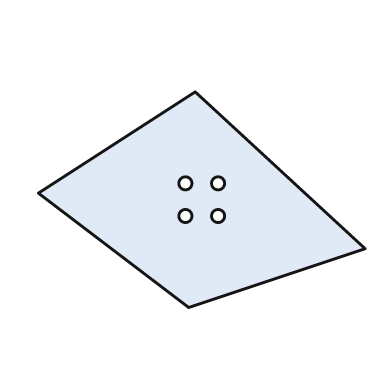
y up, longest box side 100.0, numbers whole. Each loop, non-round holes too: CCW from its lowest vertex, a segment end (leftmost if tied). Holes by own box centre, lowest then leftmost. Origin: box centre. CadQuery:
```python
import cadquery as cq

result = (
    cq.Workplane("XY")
    .moveTo(-4.0, -33.0)
    .lineTo(50.0, -15.0)
    .lineTo(-2.0, 33.0)
    .lineTo(-50.0, 2.0)
    .close()
    .moveTo(-5.0, -5.0)
    .circle(2.0)
    .moveTo(5.0, -5.0)
    .circle(2.0)
    .moveTo(-5.0, 5.0)
    .circle(2.0)
    .moveTo(5.0, 5.0)
    .circle(2.0)
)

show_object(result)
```